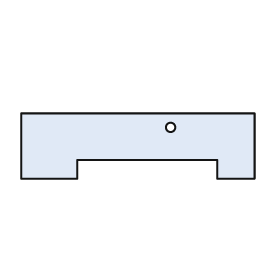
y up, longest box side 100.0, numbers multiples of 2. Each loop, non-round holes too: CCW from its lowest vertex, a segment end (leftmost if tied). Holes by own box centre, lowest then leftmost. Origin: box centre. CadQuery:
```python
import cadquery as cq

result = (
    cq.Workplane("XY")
    .moveTo(-50.0, -14.0)
    .lineTo(-26.0, -14.0)
    .lineTo(-26.0, -6.0)
    .lineTo(34.0, -6.0)
    .lineTo(34.0, -14.0)
    .lineTo(50.0, -14.0)
    .lineTo(50.0, 14.0)
    .lineTo(-50.0, 14.0)
    .close()
    .moveTo(14.0, 8.0)
    .circle(2.0)
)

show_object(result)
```